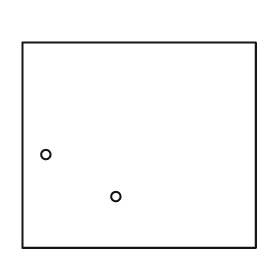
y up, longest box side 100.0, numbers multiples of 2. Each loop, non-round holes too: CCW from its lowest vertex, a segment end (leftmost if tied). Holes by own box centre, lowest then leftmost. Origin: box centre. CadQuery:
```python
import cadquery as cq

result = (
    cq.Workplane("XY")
    .moveTo(-50.0, -44.0)
    .lineTo(50.0, -44.0)
    .lineTo(50.0, 44.0)
    .lineTo(-50.0, 44.0)
    .close()
    .moveTo(-10.0, -22.0)
    .circle(2.0)
    .moveTo(-40.0, -4.0)
    .circle(2.0)
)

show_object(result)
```